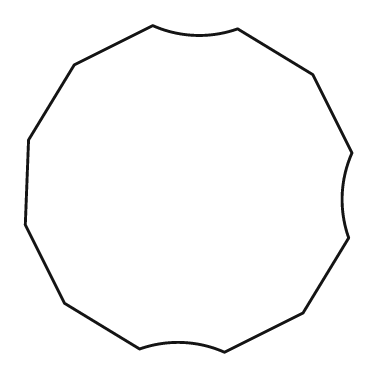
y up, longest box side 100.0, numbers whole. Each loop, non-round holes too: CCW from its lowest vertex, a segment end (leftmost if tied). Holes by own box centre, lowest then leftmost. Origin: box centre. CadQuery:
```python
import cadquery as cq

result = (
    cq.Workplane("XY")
    .moveTo(11.0, -50.0)
    .lineTo(35.0, -38.0)
    .lineTo(49.0, -15.0)
    .threePointArc((47.0, -2.0), (50.0, 11.0))
    .lineTo(38.0, 35.0)
    .lineTo(15.0, 49.0)
    .threePointArc((2.0, 47.0), (-11.0, 50.0))
    .lineTo(-35.0, 38.0)
    .lineTo(-49.0, 15.0)
    .lineTo(-50.0, -11.0)
    .lineTo(-38.0, -35.0)
    .lineTo(-15.0, -49.0)
    .threePointArc((-2.0, -47.0), (11.0, -50.0))
    .close()
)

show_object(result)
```